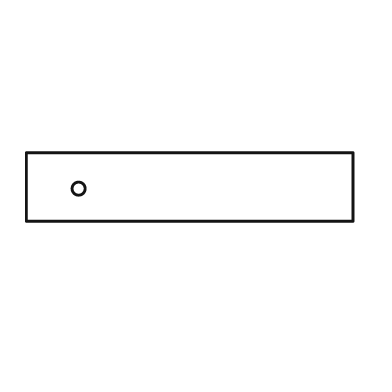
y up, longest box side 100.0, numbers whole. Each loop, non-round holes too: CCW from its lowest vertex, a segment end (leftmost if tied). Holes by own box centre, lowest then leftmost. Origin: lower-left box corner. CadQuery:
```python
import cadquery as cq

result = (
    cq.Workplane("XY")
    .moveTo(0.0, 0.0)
    .lineTo(100.0, 0.0)
    .lineTo(100.0, 21.0)
    .lineTo(0.0, 21.0)
    .close()
    .moveTo(16.0, 10.0)
    .circle(2.0)
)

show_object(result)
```